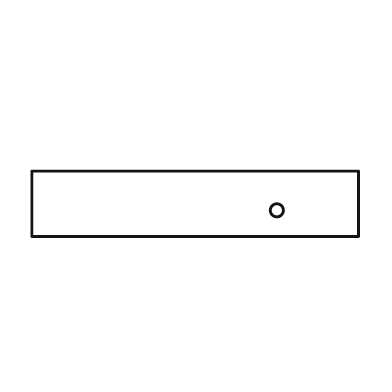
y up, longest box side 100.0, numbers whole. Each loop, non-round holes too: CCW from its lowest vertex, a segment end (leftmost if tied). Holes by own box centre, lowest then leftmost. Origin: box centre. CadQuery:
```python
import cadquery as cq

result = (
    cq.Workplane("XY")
    .moveTo(-50.0, -10.0)
    .lineTo(50.0, -10.0)
    .lineTo(50.0, 10.0)
    .lineTo(-50.0, 10.0)
    .close()
    .moveTo(25.0, -2.0)
    .circle(2.0)
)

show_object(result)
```